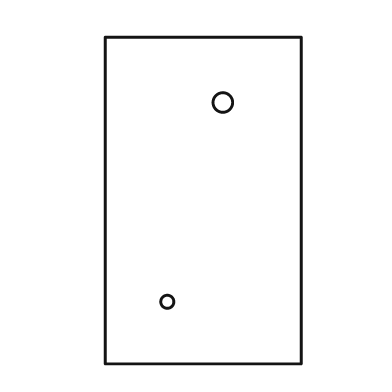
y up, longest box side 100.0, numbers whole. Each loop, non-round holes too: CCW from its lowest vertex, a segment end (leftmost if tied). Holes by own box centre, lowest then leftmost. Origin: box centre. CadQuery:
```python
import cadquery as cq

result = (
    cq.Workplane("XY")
    .moveTo(-30.0, -50.0)
    .lineTo(30.0, -50.0)
    .lineTo(30.0, 50.0)
    .lineTo(-30.0, 50.0)
    .close()
    .moveTo(-11.0, -31.0)
    .circle(2.0)
    .moveTo(6.0, 30.0)
    .circle(3.0)
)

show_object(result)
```